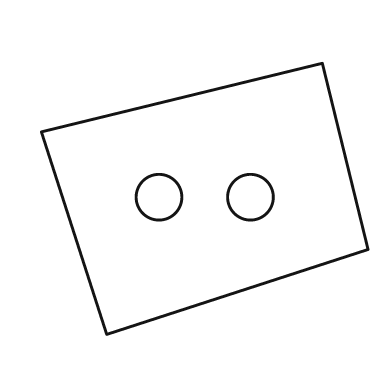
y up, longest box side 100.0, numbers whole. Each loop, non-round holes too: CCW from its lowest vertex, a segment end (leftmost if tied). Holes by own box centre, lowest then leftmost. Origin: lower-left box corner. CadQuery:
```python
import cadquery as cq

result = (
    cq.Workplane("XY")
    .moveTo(20.0, 0.0)
    .lineTo(100.0, 26.0)
    .lineTo(86.0, 83.0)
    .lineTo(0.0, 62.0)
    .close()
    .moveTo(36.0, 42.0)
    .circle(7.0)
    .moveTo(64.0, 42.0)
    .circle(7.0)
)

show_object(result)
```